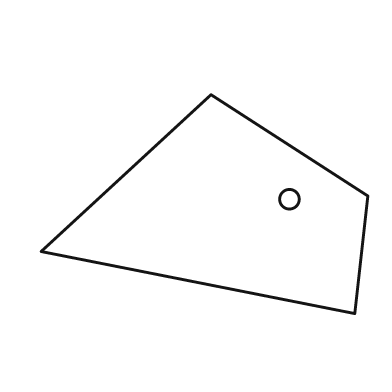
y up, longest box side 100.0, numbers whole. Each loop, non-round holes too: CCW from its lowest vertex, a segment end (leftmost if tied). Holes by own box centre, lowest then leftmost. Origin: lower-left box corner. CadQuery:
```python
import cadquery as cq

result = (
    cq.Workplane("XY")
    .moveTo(96.0, 0.0)
    .lineTo(100.0, 36.0)
    .lineTo(52.0, 67.0)
    .lineTo(0.0, 19.0)
    .close()
    .moveTo(76.0, 35.0)
    .circle(3.0)
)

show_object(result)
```